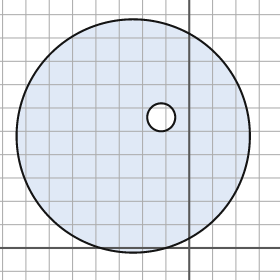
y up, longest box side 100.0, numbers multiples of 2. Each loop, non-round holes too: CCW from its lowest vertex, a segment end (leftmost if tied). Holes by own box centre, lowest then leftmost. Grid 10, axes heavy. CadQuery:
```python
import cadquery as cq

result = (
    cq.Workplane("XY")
    .moveTo(-24.0, 48.0)
    .circle(50.0)
    .moveTo(-12.0, 56.0)
    .circle(6.0)
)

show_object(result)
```